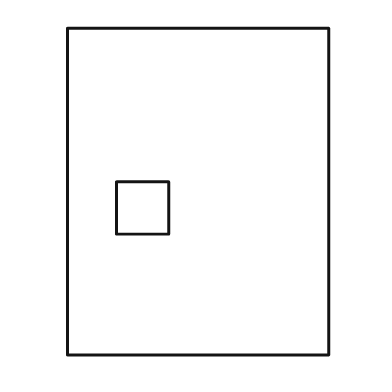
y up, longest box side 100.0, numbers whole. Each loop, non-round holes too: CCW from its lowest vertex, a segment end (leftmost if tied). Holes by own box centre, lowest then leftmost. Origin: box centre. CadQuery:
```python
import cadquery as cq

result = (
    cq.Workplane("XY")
    .moveTo(-40.0, -50.0)
    .lineTo(40.0, -50.0)
    .lineTo(40.0, 50.0)
    .lineTo(-40.0, 50.0)
    .close()
    .moveTo(-25.0, -13.0)
    .lineTo(-9.0, -13.0)
    .lineTo(-9.0, 3.0)
    .lineTo(-25.0, 3.0)
    .close()
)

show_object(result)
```